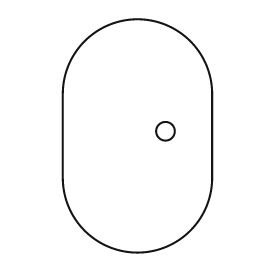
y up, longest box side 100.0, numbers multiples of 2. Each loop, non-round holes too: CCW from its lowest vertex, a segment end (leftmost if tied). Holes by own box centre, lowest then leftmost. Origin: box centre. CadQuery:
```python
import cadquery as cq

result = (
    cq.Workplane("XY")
    .moveTo(-32.0, -18.0)
    .threePointArc((0.0, -50.0), (32.0, -18.0))
    .lineTo(32.0, 18.0)
    .threePointArc((0.0, 50.0), (-32.0, 18.0))
    .close()
    .moveTo(12.0, 2.0)
    .circle(4.0)
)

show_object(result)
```